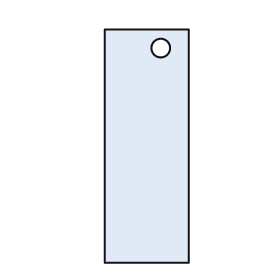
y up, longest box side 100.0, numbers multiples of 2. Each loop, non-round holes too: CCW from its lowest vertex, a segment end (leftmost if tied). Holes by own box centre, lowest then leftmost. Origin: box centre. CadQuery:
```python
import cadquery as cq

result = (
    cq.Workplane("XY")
    .moveTo(-18.0, -50.0)
    .lineTo(18.0, -50.0)
    .lineTo(18.0, 50.0)
    .lineTo(-18.0, 50.0)
    .close()
    .moveTo(6.0, 42.0)
    .circle(4.0)
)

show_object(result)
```